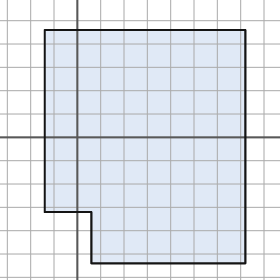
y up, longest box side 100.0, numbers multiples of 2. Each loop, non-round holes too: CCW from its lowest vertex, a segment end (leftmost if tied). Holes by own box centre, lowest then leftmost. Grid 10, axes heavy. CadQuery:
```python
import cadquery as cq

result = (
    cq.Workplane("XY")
    .moveTo(6.0, -54.0)
    .lineTo(72.0, -54.0)
    .lineTo(72.0, 46.0)
    .lineTo(-14.0, 46.0)
    .lineTo(-14.0, -32.0)
    .lineTo(6.0, -32.0)
    .close()
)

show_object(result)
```